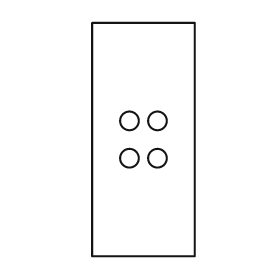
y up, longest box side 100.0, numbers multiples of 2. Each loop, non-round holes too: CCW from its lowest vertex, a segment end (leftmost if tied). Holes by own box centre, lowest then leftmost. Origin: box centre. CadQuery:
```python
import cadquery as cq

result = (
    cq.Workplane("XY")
    .moveTo(-22.0, -50.0)
    .lineTo(22.0, -50.0)
    .lineTo(22.0, 50.0)
    .lineTo(-22.0, 50.0)
    .close()
    .moveTo(-6.0, -8.0)
    .circle(4.0)
    .moveTo(6.0, -8.0)
    .circle(4.0)
    .moveTo(-6.0, 8.0)
    .circle(4.0)
    .moveTo(6.0, 8.0)
    .circle(4.0)
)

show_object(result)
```